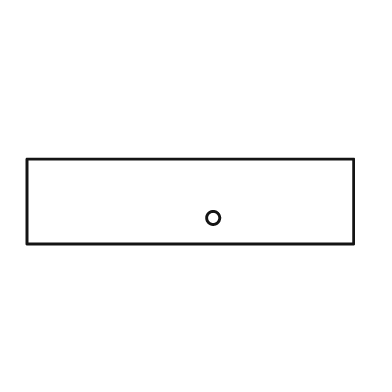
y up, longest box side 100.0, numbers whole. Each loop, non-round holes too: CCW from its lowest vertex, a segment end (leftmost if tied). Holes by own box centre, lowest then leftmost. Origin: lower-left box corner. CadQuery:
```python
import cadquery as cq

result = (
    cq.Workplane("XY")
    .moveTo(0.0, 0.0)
    .lineTo(100.0, 0.0)
    .lineTo(100.0, 26.0)
    .lineTo(0.0, 26.0)
    .close()
    .moveTo(57.0, 8.0)
    .circle(2.0)
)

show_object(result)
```